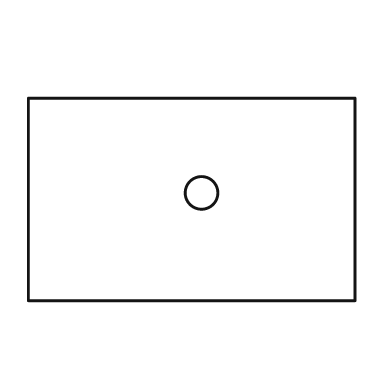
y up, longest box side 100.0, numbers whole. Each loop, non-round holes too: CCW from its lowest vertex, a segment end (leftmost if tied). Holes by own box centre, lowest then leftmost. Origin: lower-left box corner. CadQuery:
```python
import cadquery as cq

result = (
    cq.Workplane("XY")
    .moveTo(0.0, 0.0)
    .lineTo(100.0, 0.0)
    .lineTo(100.0, 62.0)
    .lineTo(0.0, 62.0)
    .close()
    .moveTo(53.0, 33.0)
    .circle(5.0)
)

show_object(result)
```